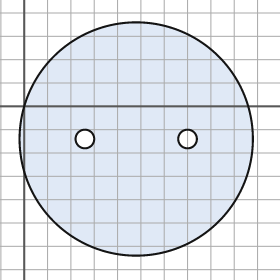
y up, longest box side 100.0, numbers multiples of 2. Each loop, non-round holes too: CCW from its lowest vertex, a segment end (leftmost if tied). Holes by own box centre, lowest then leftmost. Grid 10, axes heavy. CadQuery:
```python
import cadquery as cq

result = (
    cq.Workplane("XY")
    .moveTo(48.0, -14.0)
    .circle(50.0)
    .moveTo(26.0, -14.0)
    .circle(4.0)
    .moveTo(70.0, -14.0)
    .circle(4.0)
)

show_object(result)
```